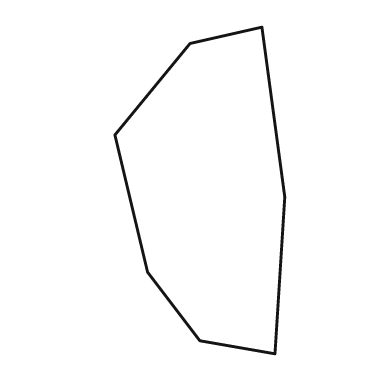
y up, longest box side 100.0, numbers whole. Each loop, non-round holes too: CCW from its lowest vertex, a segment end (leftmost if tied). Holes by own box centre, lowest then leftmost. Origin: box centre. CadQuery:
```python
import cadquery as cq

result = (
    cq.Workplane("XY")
    .moveTo(23.0, -50.0)
    .lineTo(26.0, -2.0)
    .lineTo(19.0, 50.0)
    .lineTo(-3.0, 45.0)
    .lineTo(-26.0, 17.0)
    .lineTo(-16.0, -25.0)
    .lineTo(0.0, -46.0)
    .close()
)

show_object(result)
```